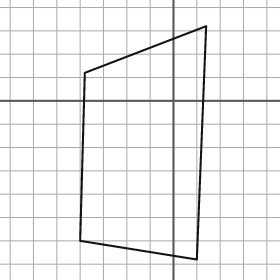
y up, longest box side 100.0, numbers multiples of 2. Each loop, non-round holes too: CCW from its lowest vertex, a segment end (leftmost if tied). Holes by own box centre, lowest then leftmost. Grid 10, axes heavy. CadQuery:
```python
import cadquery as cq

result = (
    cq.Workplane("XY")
    .moveTo(10.0, -68.0)
    .lineTo(14.0, 32.0)
    .lineTo(-38.0, 12.0)
    .lineTo(-40.0, -60.0)
    .close()
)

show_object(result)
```